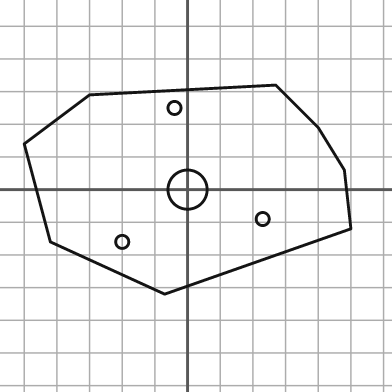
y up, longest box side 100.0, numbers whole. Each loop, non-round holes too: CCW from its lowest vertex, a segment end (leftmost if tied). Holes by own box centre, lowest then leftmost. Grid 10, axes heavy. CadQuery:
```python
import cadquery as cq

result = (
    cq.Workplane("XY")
    .moveTo(-7.0, -32.0)
    .lineTo(50.0, -12.0)
    .lineTo(48.0, 6.0)
    .lineTo(40.0, 19.0)
    .lineTo(27.0, 32.0)
    .lineTo(-30.0, 29.0)
    .lineTo(-50.0, 14.0)
    .lineTo(-42.0, -16.0)
    .close()
    .moveTo(-20.0, -16.0)
    .circle(2.0)
    .moveTo(23.0, -9.0)
    .circle(2.0)
    .moveTo(0.0, 0.0)
    .circle(6.0)
    .moveTo(-4.0, 25.0)
    .circle(2.0)
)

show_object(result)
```